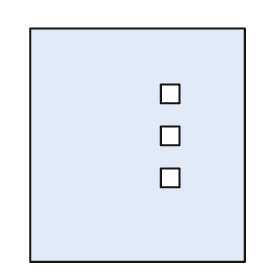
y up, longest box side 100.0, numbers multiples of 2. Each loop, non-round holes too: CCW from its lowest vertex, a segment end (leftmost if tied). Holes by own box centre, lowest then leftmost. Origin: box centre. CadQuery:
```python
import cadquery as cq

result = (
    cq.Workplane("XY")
    .moveTo(-46.0, -50.0)
    .lineTo(46.0, -50.0)
    .lineTo(46.0, 50.0)
    .lineTo(-46.0, 50.0)
    .close()
    .moveTo(10.0, -18.0)
    .lineTo(18.0, -18.0)
    .lineTo(18.0, -10.0)
    .lineTo(10.0, -10.0)
    .close()
    .moveTo(10.0, 0.0)
    .lineTo(18.0, 0.0)
    .lineTo(18.0, 8.0)
    .lineTo(10.0, 8.0)
    .close()
    .moveTo(10.0, 18.0)
    .lineTo(18.0, 18.0)
    .lineTo(18.0, 26.0)
    .lineTo(10.0, 26.0)
    .close()
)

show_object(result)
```